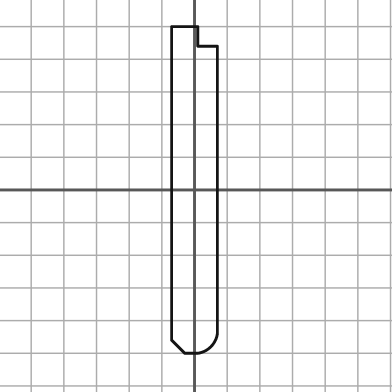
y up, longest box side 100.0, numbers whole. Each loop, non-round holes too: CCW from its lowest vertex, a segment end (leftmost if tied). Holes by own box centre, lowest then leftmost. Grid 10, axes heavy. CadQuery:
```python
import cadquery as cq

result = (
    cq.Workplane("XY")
    .moveTo(-3.0, -50.0)
    .lineTo(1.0, -50.0)
    .threePointArc((5.0, -48.0), (7.0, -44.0))
    .lineTo(7.0, 44.0)
    .lineTo(1.0, 44.0)
    .lineTo(1.0, 50.0)
    .lineTo(-7.0, 50.0)
    .lineTo(-7.0, -46.0)
    .close()
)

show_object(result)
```